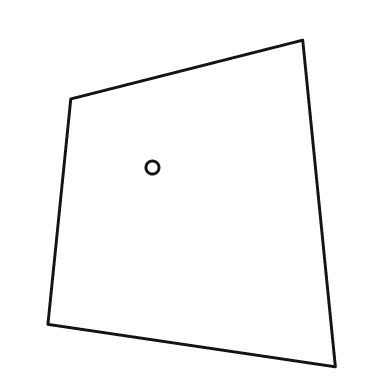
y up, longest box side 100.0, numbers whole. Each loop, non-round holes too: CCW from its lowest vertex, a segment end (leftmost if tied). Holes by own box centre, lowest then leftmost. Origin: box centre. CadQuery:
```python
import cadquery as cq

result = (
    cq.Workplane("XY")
    .moveTo(44.0, -50.0)
    .lineTo(34.0, 50.0)
    .lineTo(-37.0, 32.0)
    .lineTo(-44.0, -37.0)
    .close()
    .moveTo(-12.0, 11.0)
    .circle(2.0)
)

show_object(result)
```